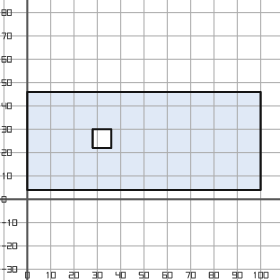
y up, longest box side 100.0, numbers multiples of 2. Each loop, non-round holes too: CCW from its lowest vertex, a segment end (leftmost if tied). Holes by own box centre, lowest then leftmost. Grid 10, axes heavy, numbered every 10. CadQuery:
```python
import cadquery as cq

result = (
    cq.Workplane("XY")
    .moveTo(0.0, 4.0)
    .lineTo(100.0, 4.0)
    .lineTo(100.0, 46.0)
    .lineTo(0.0, 46.0)
    .close()
    .moveTo(28.0, 22.0)
    .lineTo(36.0, 22.0)
    .lineTo(36.0, 30.0)
    .lineTo(28.0, 30.0)
    .close()
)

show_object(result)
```